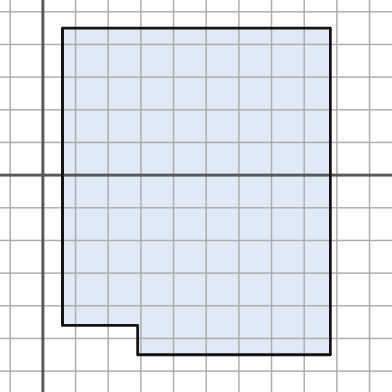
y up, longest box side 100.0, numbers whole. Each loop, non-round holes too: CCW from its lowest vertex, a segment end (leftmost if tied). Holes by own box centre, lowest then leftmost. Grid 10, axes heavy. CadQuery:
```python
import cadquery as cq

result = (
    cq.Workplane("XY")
    .moveTo(29.0, -55.0)
    .lineTo(88.0, -55.0)
    .lineTo(88.0, 45.0)
    .lineTo(6.0, 45.0)
    .lineTo(6.0, -46.0)
    .lineTo(29.0, -46.0)
    .close()
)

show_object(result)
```